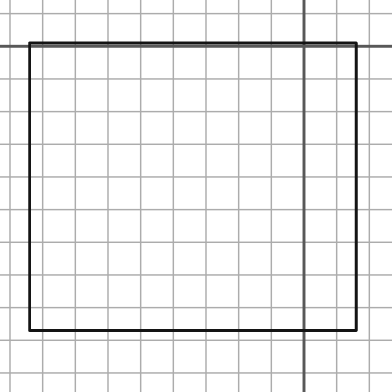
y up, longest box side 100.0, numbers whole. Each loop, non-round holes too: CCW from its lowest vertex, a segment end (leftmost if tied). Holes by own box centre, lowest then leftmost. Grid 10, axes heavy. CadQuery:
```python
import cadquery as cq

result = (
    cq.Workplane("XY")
    .moveTo(-84.0, -87.0)
    .lineTo(16.0, -87.0)
    .lineTo(16.0, 1.0)
    .lineTo(-84.0, 1.0)
    .close()
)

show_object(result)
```